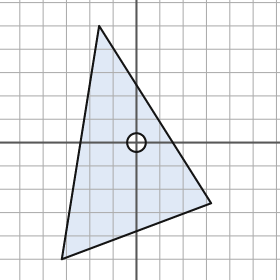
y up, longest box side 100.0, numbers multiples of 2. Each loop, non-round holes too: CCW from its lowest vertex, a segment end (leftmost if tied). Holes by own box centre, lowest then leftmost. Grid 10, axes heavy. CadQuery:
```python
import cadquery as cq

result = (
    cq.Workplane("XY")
    .moveTo(-32.0, -50.0)
    .lineTo(32.0, -26.0)
    .lineTo(-16.0, 50.0)
    .close()
    .moveTo(0.0, 0.0)
    .circle(4.0)
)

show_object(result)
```